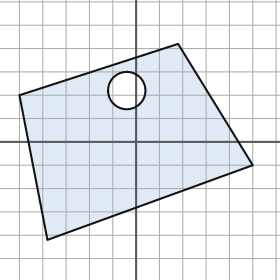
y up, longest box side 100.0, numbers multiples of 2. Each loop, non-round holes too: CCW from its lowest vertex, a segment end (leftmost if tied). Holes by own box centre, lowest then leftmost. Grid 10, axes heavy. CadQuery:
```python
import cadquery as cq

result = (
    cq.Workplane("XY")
    .moveTo(-38.0, -42.0)
    .lineTo(50.0, -10.0)
    .lineTo(18.0, 42.0)
    .lineTo(-50.0, 20.0)
    .close()
    .moveTo(-4.0, 22.0)
    .circle(8.0)
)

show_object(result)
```